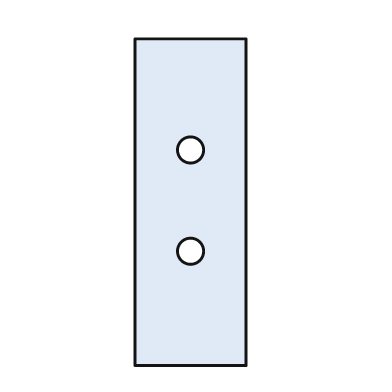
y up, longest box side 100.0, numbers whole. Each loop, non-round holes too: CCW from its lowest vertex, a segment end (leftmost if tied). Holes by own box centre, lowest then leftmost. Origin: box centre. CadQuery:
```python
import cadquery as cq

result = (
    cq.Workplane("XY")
    .moveTo(-17.0, -50.0)
    .lineTo(17.0, -50.0)
    .lineTo(17.0, 50.0)
    .lineTo(-17.0, 50.0)
    .close()
    .moveTo(0.0, -15.0)
    .circle(4.0)
    .moveTo(0.0, 16.0)
    .circle(4.0)
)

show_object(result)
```